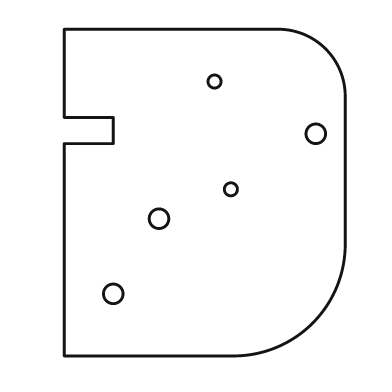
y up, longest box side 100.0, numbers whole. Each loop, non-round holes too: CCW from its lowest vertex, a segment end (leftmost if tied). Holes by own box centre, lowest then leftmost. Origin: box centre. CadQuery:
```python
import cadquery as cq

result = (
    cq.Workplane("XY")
    .moveTo(-43.0, -50.0)
    .lineTo(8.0, -50.0)
    .threePointArc((33.0, -40.0), (43.0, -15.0))
    .lineTo(43.0, 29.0)
    .threePointArc((37.0, 44.0), (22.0, 50.0))
    .lineTo(-43.0, 50.0)
    .lineTo(-43.0, 23.0)
    .lineTo(-28.0, 23.0)
    .lineTo(-28.0, 15.0)
    .lineTo(-43.0, 15.0)
    .close()
    .moveTo(-28.0, -31.0)
    .circle(3.0)
    .moveTo(-14.0, -8.0)
    .circle(3.0)
    .moveTo(8.0, 1.0)
    .circle(2.0)
    .moveTo(34.0, 18.0)
    .circle(3.0)
    .moveTo(3.0, 34.0)
    .circle(2.0)
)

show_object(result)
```